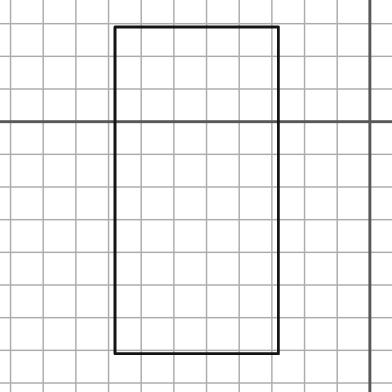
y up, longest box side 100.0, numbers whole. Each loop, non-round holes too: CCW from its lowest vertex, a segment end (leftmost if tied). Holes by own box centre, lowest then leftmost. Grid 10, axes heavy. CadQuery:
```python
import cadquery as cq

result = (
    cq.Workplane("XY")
    .moveTo(-78.0, -71.0)
    .lineTo(-28.0, -71.0)
    .lineTo(-28.0, 29.0)
    .lineTo(-78.0, 29.0)
    .close()
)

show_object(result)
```